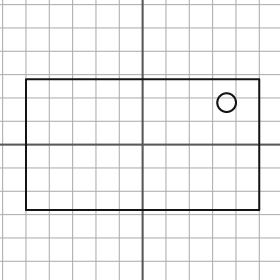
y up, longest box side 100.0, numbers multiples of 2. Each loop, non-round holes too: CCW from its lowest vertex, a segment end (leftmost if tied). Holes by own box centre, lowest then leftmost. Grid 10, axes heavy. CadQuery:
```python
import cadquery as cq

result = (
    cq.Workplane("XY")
    .moveTo(-50.0, -28.0)
    .lineTo(50.0, -28.0)
    .lineTo(50.0, 28.0)
    .lineTo(-50.0, 28.0)
    .close()
    .moveTo(36.0, 18.0)
    .circle(4.0)
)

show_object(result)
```